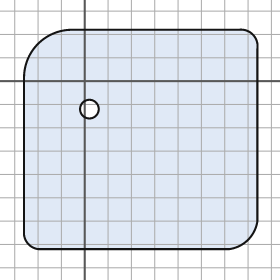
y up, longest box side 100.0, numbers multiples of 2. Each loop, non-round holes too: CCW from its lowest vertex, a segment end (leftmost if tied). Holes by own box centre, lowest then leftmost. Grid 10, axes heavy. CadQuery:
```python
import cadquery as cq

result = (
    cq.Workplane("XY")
    .moveTo(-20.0, -72.0)
    .lineTo(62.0, -72.0)
    .threePointArc((70.0, -68.0), (74.0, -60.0))
    .lineTo(74.0, 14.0)
    .threePointArc((72.0, 20.0), (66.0, 22.0))
    .lineTo(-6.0, 22.0)
    .threePointArc((-20.0, 16.0), (-26.0, 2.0))
    .lineTo(-26.0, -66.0)
    .threePointArc((-24.0, -70.0), (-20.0, -72.0))
    .close()
    .moveTo(2.0, -12.0)
    .circle(4.0)
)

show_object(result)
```